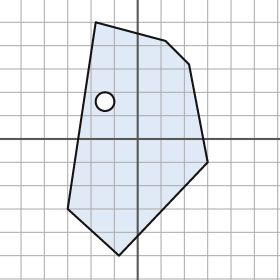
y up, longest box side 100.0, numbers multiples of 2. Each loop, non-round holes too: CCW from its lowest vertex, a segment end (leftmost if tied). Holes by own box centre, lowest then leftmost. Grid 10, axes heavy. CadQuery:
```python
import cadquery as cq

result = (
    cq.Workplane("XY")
    .moveTo(-8.0, -50.0)
    .lineTo(30.0, -10.0)
    .lineTo(22.0, 32.0)
    .lineTo(12.0, 42.0)
    .lineTo(-18.0, 50.0)
    .lineTo(-30.0, -30.0)
    .close()
    .moveTo(-14.0, 16.0)
    .circle(4.0)
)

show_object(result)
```